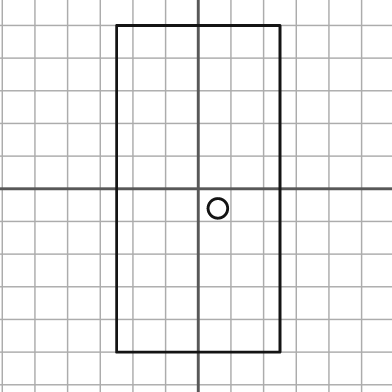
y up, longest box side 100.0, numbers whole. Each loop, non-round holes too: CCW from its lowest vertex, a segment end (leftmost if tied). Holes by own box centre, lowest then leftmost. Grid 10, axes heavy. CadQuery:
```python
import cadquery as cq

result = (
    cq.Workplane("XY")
    .moveTo(-25.0, -50.0)
    .lineTo(25.0, -50.0)
    .lineTo(25.0, 50.0)
    .lineTo(-25.0, 50.0)
    .close()
    .moveTo(6.0, -6.0)
    .circle(3.0)
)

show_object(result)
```